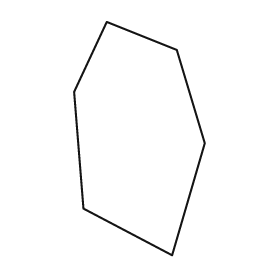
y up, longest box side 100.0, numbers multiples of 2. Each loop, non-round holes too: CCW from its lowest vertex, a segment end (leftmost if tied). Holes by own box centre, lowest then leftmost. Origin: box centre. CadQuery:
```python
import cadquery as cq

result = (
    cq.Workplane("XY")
    .moveTo(14.0, -50.0)
    .lineTo(28.0, -2.0)
    .lineTo(16.0, 38.0)
    .lineTo(-14.0, 50.0)
    .lineTo(-28.0, 20.0)
    .lineTo(-24.0, -30.0)
    .close()
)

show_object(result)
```